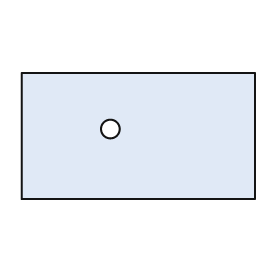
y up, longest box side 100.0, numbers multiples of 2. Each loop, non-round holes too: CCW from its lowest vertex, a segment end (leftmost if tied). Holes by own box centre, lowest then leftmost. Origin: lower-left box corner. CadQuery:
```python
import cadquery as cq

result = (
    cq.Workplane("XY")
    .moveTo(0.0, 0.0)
    .lineTo(100.0, 0.0)
    .lineTo(100.0, 54.0)
    .lineTo(0.0, 54.0)
    .close()
    .moveTo(38.0, 30.0)
    .circle(4.0)
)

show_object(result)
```